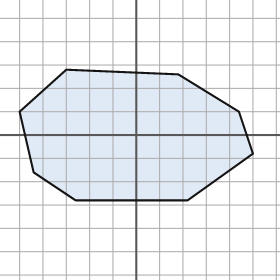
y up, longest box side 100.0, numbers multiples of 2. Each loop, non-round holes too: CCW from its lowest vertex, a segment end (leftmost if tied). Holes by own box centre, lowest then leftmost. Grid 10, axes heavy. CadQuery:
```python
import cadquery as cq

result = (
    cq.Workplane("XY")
    .moveTo(-26.0, -28.0)
    .lineTo(22.0, -28.0)
    .lineTo(50.0, -8.0)
    .lineTo(44.0, 10.0)
    .lineTo(18.0, 26.0)
    .lineTo(-30.0, 28.0)
    .lineTo(-50.0, 10.0)
    .lineTo(-44.0, -16.0)
    .close()
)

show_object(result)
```